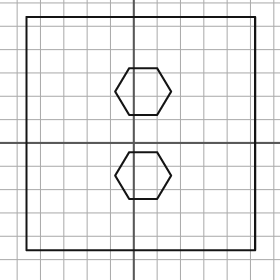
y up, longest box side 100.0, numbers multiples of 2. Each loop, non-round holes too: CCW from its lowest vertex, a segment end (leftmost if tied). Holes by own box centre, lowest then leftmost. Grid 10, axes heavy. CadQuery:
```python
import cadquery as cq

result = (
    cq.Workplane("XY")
    .moveTo(-46.0, -46.0)
    .lineTo(52.0, -46.0)
    .lineTo(52.0, 54.0)
    .lineTo(-46.0, 54.0)
    .close()
    .moveTo(-2.0, -24.0)
    .lineTo(10.0, -24.0)
    .lineTo(16.0, -14.0)
    .lineTo(10.0, -4.0)
    .lineTo(-2.0, -4.0)
    .lineTo(-8.0, -14.0)
    .close()
    .moveTo(-2.0, 12.0)
    .lineTo(10.0, 12.0)
    .lineTo(16.0, 22.0)
    .lineTo(10.0, 32.0)
    .lineTo(-2.0, 32.0)
    .lineTo(-8.0, 22.0)
    .close()
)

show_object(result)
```